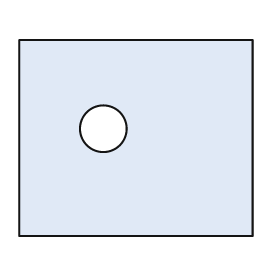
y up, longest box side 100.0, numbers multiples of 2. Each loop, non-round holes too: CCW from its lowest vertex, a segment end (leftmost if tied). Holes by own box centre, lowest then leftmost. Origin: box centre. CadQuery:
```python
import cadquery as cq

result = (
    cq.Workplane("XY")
    .moveTo(-50.0, -42.0)
    .lineTo(50.0, -42.0)
    .lineTo(50.0, 42.0)
    .lineTo(-50.0, 42.0)
    .close()
    .moveTo(-14.0, 4.0)
    .circle(10.0)
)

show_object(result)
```